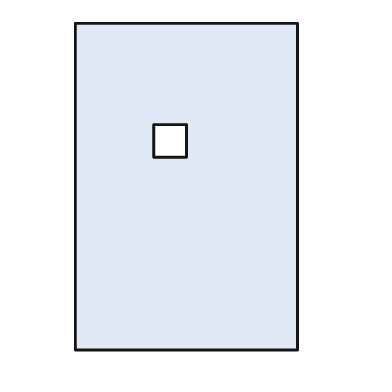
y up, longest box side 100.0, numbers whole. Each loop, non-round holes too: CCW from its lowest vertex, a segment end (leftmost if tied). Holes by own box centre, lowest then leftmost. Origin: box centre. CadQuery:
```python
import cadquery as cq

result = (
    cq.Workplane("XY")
    .moveTo(-34.0, -50.0)
    .lineTo(34.0, -50.0)
    .lineTo(34.0, 50.0)
    .lineTo(-34.0, 50.0)
    .close()
    .moveTo(-10.0, 9.0)
    .lineTo(0.0, 9.0)
    .lineTo(0.0, 19.0)
    .lineTo(-10.0, 19.0)
    .close()
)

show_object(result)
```